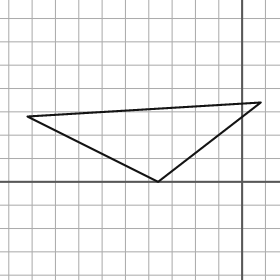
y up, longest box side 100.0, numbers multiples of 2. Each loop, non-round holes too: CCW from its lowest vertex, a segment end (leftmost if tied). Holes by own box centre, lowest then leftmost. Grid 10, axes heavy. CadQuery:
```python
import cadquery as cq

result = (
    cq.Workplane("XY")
    .moveTo(-36.0, 0.0)
    .lineTo(8.0, 34.0)
    .lineTo(-92.0, 28.0)
    .close()
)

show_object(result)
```